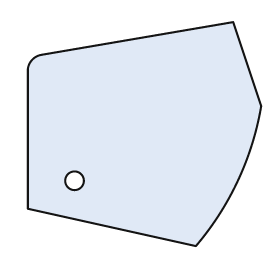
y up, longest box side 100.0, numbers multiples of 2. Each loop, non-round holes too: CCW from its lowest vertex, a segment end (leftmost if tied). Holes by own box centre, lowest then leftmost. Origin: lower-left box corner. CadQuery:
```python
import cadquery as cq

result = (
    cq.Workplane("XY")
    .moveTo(72.0, 0.0)
    .threePointArc((90.0, 28.0), (100.0, 60.0))
    .lineTo(88.0, 96.0)
    .lineTo(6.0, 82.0)
    .threePointArc((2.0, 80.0), (0.0, 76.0))
    .lineTo(0.0, 16.0)
    .close()
    .moveTo(20.0, 28.0)
    .circle(4.0)
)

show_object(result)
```